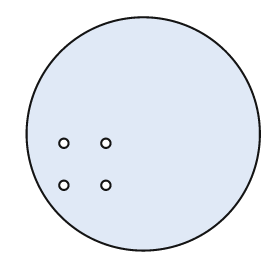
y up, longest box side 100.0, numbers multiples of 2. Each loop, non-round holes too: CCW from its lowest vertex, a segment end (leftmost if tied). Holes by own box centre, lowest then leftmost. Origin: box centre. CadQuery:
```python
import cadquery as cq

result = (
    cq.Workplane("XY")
    .moveTo(0.0, 0.0)
    .circle(50.0)
    .moveTo(-34.0, -22.0)
    .circle(2.0)
    .moveTo(-16.0, -22.0)
    .circle(2.0)
    .moveTo(-34.0, -4.0)
    .circle(2.0)
    .moveTo(-16.0, -4.0)
    .circle(2.0)
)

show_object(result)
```